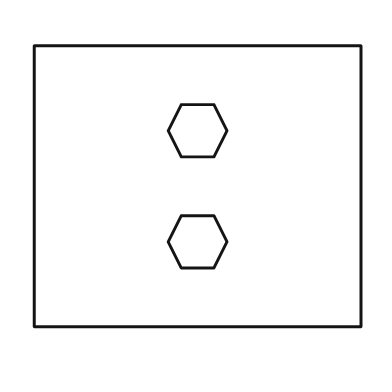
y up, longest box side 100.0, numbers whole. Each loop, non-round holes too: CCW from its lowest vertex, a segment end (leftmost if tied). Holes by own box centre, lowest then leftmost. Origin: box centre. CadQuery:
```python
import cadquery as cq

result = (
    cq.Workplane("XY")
    .moveTo(-50.0, -43.0)
    .lineTo(50.0, -43.0)
    .lineTo(50.0, 43.0)
    .lineTo(-50.0, 43.0)
    .close()
    .moveTo(-5.0, -25.0)
    .lineTo(5.0, -25.0)
    .lineTo(9.0, -17.0)
    .lineTo(5.0, -9.0)
    .lineTo(-5.0, -9.0)
    .lineTo(-9.0, -17.0)
    .close()
    .moveTo(-5.0, 9.0)
    .lineTo(5.0, 9.0)
    .lineTo(9.0, 17.0)
    .lineTo(5.0, 25.0)
    .lineTo(-5.0, 25.0)
    .lineTo(-9.0, 17.0)
    .close()
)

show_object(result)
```